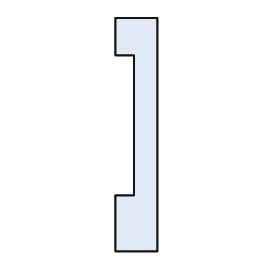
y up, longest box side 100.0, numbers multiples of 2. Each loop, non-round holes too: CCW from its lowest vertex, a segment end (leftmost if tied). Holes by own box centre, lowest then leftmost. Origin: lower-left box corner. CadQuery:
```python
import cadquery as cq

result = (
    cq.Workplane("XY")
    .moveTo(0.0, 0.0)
    .lineTo(18.0, 0.0)
    .lineTo(18.0, 100.0)
    .lineTo(0.0, 100.0)
    .lineTo(0.0, 84.0)
    .lineTo(8.0, 84.0)
    .lineTo(8.0, 24.0)
    .lineTo(0.0, 24.0)
    .close()
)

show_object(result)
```